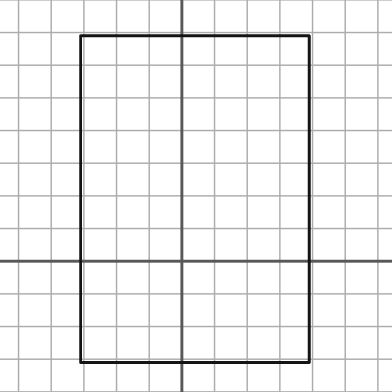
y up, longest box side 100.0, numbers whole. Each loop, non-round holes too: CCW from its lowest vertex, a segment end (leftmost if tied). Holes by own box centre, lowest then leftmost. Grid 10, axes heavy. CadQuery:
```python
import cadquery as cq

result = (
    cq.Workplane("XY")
    .moveTo(-31.0, -31.0)
    .lineTo(39.0, -31.0)
    .lineTo(39.0, 69.0)
    .lineTo(-31.0, 69.0)
    .close()
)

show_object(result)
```